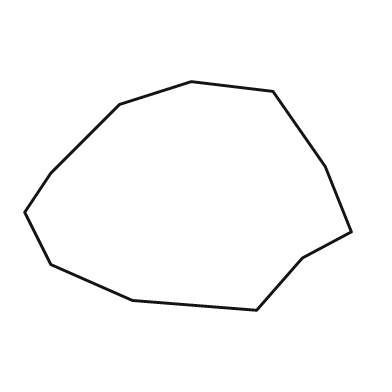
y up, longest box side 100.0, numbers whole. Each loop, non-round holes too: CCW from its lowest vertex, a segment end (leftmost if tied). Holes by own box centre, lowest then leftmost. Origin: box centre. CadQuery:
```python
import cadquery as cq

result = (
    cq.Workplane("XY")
    .moveTo(21.0, -35.0)
    .lineTo(35.0, -19.0)
    .lineTo(50.0, -11.0)
    .lineTo(42.0, 9.0)
    .lineTo(26.0, 32.0)
    .lineTo(1.0, 35.0)
    .lineTo(-21.0, 28.0)
    .lineTo(-42.0, 7.0)
    .lineTo(-50.0, -5.0)
    .lineTo(-42.0, -21.0)
    .lineTo(-17.0, -32.0)
    .close()
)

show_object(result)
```